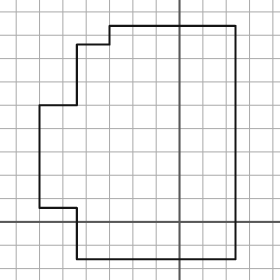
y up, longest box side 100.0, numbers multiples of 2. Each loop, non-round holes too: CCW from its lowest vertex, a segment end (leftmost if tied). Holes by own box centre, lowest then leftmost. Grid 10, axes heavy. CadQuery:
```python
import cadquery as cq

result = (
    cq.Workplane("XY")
    .moveTo(-44.0, -16.0)
    .lineTo(24.0, -16.0)
    .lineTo(24.0, 84.0)
    .lineTo(-30.0, 84.0)
    .lineTo(-30.0, 76.0)
    .lineTo(-44.0, 76.0)
    .lineTo(-44.0, 50.0)
    .lineTo(-60.0, 50.0)
    .lineTo(-60.0, 6.0)
    .lineTo(-44.0, 6.0)
    .close()
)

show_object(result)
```